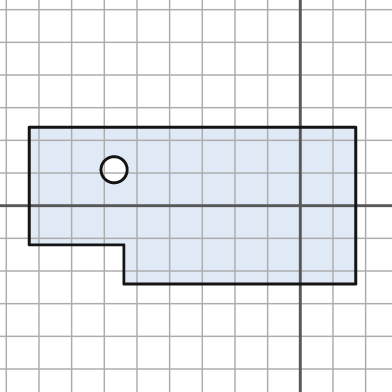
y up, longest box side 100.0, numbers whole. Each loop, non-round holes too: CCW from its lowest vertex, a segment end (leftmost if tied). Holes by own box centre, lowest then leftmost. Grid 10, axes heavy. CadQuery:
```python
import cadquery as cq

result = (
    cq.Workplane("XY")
    .moveTo(-54.0, -24.0)
    .lineTo(17.0, -24.0)
    .lineTo(17.0, 24.0)
    .lineTo(-83.0, 24.0)
    .lineTo(-83.0, -12.0)
    .lineTo(-54.0, -12.0)
    .close()
    .moveTo(-57.0, 11.0)
    .circle(4.0)
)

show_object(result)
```